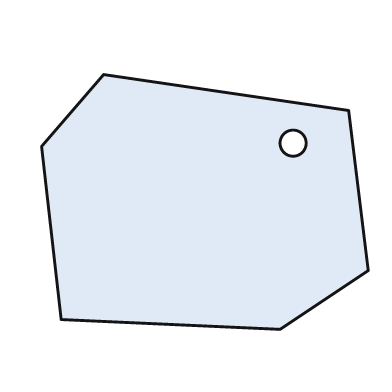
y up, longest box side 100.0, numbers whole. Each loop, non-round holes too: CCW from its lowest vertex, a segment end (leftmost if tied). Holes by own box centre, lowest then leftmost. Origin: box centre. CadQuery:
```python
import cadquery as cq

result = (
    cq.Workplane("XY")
    .moveTo(23.0, -39.0)
    .lineTo(50.0, -21.0)
    .lineTo(44.0, 28.0)
    .lineTo(-31.0, 39.0)
    .lineTo(-50.0, 17.0)
    .lineTo(-44.0, -36.0)
    .close()
    .moveTo(27.0, 18.0)
    .circle(4.0)
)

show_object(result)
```